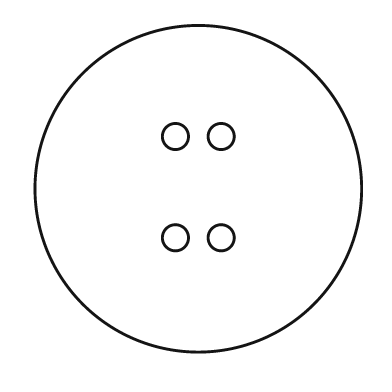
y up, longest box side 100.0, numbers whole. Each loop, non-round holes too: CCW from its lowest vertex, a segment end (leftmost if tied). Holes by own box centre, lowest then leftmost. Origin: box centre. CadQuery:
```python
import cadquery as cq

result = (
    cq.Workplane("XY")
    .moveTo(0.0, 0.0)
    .circle(50.0)
    .moveTo(-7.0, -15.0)
    .circle(4.0)
    .moveTo(7.0, -15.0)
    .circle(4.0)
    .moveTo(-7.0, 16.0)
    .circle(4.0)
    .moveTo(7.0, 16.0)
    .circle(4.0)
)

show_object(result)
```